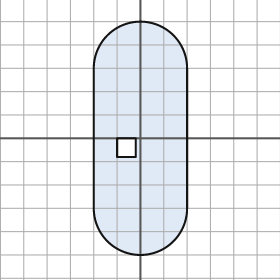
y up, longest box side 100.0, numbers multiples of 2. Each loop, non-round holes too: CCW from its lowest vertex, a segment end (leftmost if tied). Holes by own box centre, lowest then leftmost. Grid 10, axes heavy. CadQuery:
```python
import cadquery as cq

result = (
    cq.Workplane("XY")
    .moveTo(-20.0, -30.0)
    .threePointArc((0.0, -50.0), (20.0, -30.0))
    .lineTo(20.0, 30.0)
    .threePointArc((0.0, 50.0), (-20.0, 30.0))
    .close()
    .moveTo(-10.0, -8.0)
    .lineTo(-2.0, -8.0)
    .lineTo(-2.0, 0.0)
    .lineTo(-10.0, 0.0)
    .close()
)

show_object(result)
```